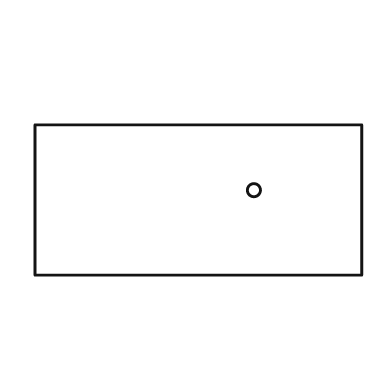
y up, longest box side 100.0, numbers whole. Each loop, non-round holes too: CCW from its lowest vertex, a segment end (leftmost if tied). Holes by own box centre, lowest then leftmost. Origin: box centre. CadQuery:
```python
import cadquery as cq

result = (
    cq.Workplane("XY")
    .moveTo(-50.0, -23.0)
    .lineTo(50.0, -23.0)
    .lineTo(50.0, 23.0)
    .lineTo(-50.0, 23.0)
    .close()
    .moveTo(17.0, 3.0)
    .circle(2.0)
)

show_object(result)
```